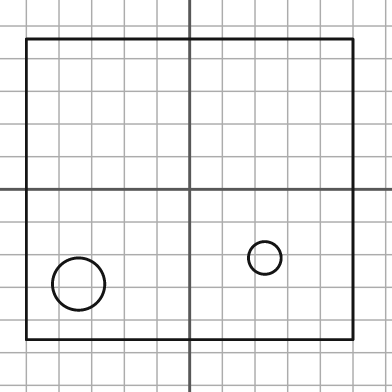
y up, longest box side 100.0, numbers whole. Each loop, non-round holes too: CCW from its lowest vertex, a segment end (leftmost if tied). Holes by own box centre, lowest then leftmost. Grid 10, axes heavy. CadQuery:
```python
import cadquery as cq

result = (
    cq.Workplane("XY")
    .moveTo(-50.0, -46.0)
    .lineTo(50.0, -46.0)
    .lineTo(50.0, 46.0)
    .lineTo(-50.0, 46.0)
    .close()
    .moveTo(-34.0, -29.0)
    .circle(8.0)
    .moveTo(23.0, -21.0)
    .circle(5.0)
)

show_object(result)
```